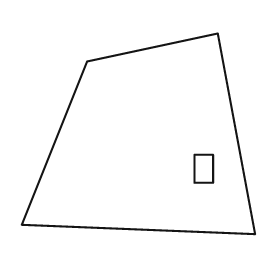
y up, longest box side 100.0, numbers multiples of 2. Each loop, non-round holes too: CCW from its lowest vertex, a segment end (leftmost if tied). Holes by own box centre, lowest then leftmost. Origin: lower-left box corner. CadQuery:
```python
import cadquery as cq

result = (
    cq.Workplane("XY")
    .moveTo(100.0, 0.0)
    .lineTo(84.0, 86.0)
    .lineTo(28.0, 74.0)
    .lineTo(0.0, 4.0)
    .close()
    .moveTo(74.0, 22.0)
    .lineTo(82.0, 22.0)
    .lineTo(82.0, 34.0)
    .lineTo(74.0, 34.0)
    .close()
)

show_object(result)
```